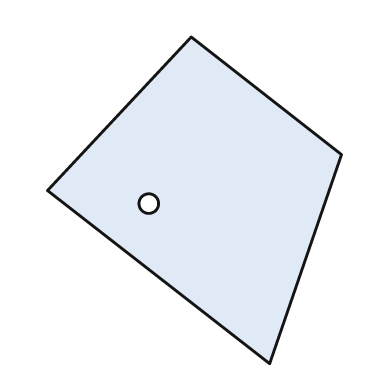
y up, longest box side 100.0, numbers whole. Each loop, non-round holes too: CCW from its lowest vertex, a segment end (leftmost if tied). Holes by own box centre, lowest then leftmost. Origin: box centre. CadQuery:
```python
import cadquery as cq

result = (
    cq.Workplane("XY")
    .moveTo(23.0, -50.0)
    .lineTo(45.0, 14.0)
    .lineTo(-1.0, 50.0)
    .lineTo(-45.0, 3.0)
    .close()
    .moveTo(-14.0, -1.0)
    .circle(3.0)
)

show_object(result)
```